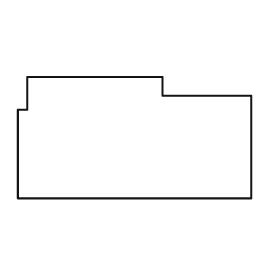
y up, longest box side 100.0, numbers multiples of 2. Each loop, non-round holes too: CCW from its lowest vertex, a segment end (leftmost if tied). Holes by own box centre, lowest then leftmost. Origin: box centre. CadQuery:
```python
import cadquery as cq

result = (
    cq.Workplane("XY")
    .moveTo(-50.0, -26.0)
    .lineTo(50.0, -26.0)
    .lineTo(50.0, 18.0)
    .lineTo(12.0, 18.0)
    .lineTo(12.0, 26.0)
    .lineTo(-46.0, 26.0)
    .lineTo(-46.0, 12.0)
    .lineTo(-50.0, 12.0)
    .close()
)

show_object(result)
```